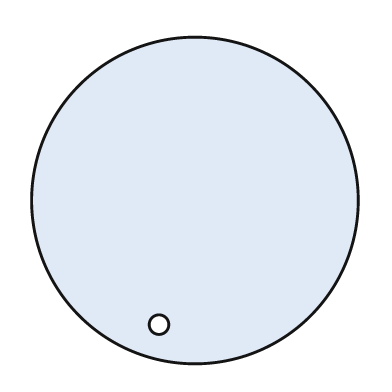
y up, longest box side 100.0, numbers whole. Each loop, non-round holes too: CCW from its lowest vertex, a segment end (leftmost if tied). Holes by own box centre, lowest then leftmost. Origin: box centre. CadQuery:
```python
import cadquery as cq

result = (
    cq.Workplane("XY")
    .moveTo(0.0, 0.0)
    .circle(50.0)
    .moveTo(-11.0, -38.0)
    .circle(3.0)
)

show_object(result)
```